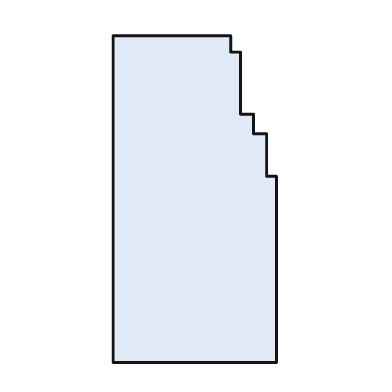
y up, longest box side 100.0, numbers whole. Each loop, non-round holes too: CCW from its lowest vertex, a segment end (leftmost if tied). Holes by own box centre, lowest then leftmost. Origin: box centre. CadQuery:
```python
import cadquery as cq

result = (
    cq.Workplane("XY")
    .moveTo(-25.0, -50.0)
    .lineTo(25.0, -50.0)
    .lineTo(25.0, 7.0)
    .lineTo(22.0, 7.0)
    .lineTo(22.0, 20.0)
    .lineTo(18.0, 20.0)
    .lineTo(18.0, 26.0)
    .lineTo(14.0, 26.0)
    .lineTo(14.0, 45.0)
    .lineTo(11.0, 45.0)
    .lineTo(11.0, 50.0)
    .lineTo(-25.0, 50.0)
    .close()
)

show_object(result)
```